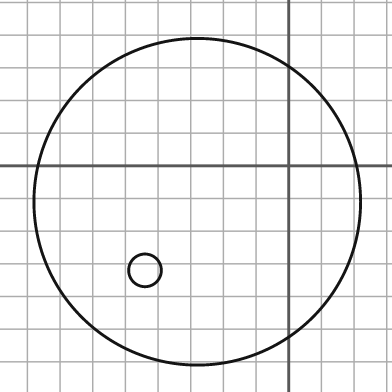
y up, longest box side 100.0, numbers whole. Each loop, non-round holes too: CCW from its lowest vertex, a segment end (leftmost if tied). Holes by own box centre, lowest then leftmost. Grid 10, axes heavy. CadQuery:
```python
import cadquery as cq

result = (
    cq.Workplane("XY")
    .moveTo(-28.0, -11.0)
    .circle(50.0)
    .moveTo(-44.0, -32.0)
    .circle(5.0)
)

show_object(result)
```